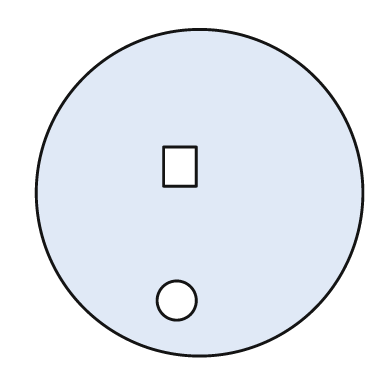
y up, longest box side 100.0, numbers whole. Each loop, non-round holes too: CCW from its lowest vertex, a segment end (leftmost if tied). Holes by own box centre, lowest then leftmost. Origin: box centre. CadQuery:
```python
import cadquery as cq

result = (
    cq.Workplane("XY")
    .moveTo(0.0, 0.0)
    .circle(50.0)
    .moveTo(-7.0, -33.0)
    .circle(6.0)
    .moveTo(-11.0, 2.0)
    .lineTo(-1.0, 2.0)
    .lineTo(-1.0, 14.0)
    .lineTo(-11.0, 14.0)
    .close()
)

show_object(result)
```